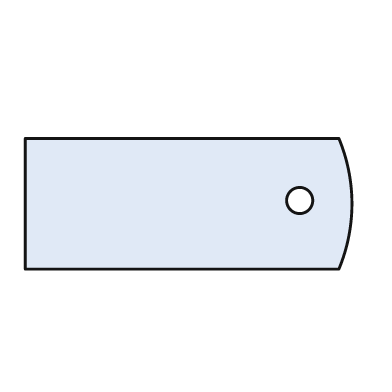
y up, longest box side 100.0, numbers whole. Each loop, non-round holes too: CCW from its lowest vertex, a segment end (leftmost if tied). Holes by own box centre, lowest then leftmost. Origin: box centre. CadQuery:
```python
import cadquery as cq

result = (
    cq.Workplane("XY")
    .moveTo(-50.0, -20.0)
    .lineTo(46.0, -20.0)
    .threePointArc((50.0, 0.0), (46.0, 20.0))
    .lineTo(-50.0, 20.0)
    .close()
    .moveTo(34.0, 1.0)
    .circle(4.0)
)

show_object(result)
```